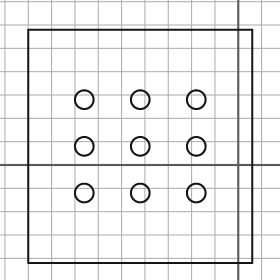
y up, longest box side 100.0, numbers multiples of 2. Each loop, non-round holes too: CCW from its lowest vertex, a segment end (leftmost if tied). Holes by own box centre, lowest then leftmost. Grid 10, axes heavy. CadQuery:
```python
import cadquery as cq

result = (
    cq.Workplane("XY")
    .moveTo(-90.0, -42.0)
    .lineTo(6.0, -42.0)
    .lineTo(6.0, 58.0)
    .lineTo(-90.0, 58.0)
    .close()
    .moveTo(-66.0, -12.0)
    .circle(4.0)
    .moveTo(-42.0, -12.0)
    .circle(4.0)
    .moveTo(-18.0, -12.0)
    .circle(4.0)
    .moveTo(-66.0, 8.0)
    .circle(4.0)
    .moveTo(-42.0, 8.0)
    .circle(4.0)
    .moveTo(-18.0, 8.0)
    .circle(4.0)
    .moveTo(-66.0, 28.0)
    .circle(4.0)
    .moveTo(-42.0, 28.0)
    .circle(4.0)
    .moveTo(-18.0, 28.0)
    .circle(4.0)
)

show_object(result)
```